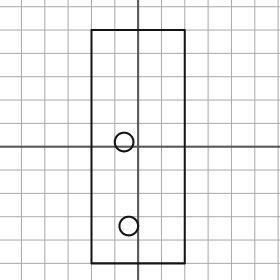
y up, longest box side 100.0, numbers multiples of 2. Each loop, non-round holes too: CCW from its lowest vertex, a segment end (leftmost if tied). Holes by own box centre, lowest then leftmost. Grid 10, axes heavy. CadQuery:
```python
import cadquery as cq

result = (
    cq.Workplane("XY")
    .moveTo(-20.0, -50.0)
    .lineTo(20.0, -50.0)
    .lineTo(20.0, 50.0)
    .lineTo(-20.0, 50.0)
    .close()
    .moveTo(-4.0, -34.0)
    .circle(4.0)
    .moveTo(-6.0, 2.0)
    .circle(4.0)
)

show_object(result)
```